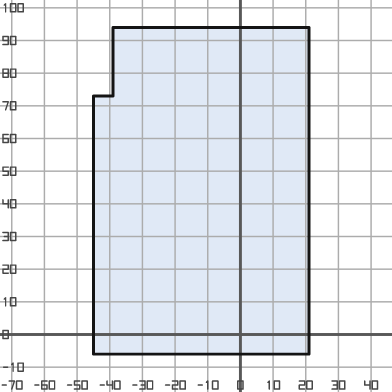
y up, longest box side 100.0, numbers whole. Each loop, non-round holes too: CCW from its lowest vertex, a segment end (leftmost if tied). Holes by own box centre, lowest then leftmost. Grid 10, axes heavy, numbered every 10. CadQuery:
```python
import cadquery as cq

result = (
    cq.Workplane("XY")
    .moveTo(-45.0, -6.0)
    .lineTo(21.0, -6.0)
    .lineTo(21.0, 94.0)
    .lineTo(-39.0, 94.0)
    .lineTo(-39.0, 73.0)
    .lineTo(-45.0, 73.0)
    .close()
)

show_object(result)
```